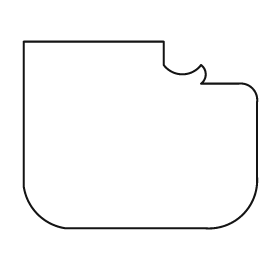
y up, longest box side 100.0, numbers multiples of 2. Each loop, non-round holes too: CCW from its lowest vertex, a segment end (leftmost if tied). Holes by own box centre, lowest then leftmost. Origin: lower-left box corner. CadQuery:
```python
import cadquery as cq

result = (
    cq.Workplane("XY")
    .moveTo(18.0, 0.0)
    .lineTo(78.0, 0.0)
    .threePointArc((94.0, 6.0), (100.0, 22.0))
    .lineTo(100.0, 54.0)
    .threePointArc((98.0, 60.0), (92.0, 62.0))
    .lineTo(76.0, 62.0)
    .threePointArc((78.0, 66.0), (76.0, 70.0))
    .threePointArc((68.0, 66.0), (60.0, 70.0))
    .lineTo(60.0, 80.0)
    .lineTo(0.0, 80.0)
    .lineTo(0.0, 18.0)
    .threePointArc((6.0, 6.0), (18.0, 0.0))
    .close()
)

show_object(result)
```